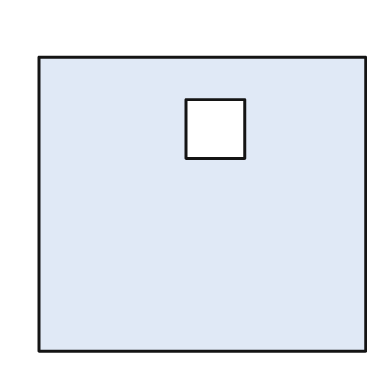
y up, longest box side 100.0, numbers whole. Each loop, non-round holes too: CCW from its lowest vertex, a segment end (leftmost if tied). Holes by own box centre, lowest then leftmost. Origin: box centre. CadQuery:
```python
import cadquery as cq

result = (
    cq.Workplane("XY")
    .moveTo(-50.0, -45.0)
    .lineTo(50.0, -45.0)
    .lineTo(50.0, 45.0)
    .lineTo(-50.0, 45.0)
    .close()
    .moveTo(-5.0, 14.0)
    .lineTo(13.0, 14.0)
    .lineTo(13.0, 32.0)
    .lineTo(-5.0, 32.0)
    .close()
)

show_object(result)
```